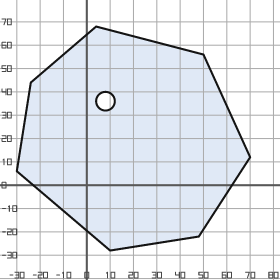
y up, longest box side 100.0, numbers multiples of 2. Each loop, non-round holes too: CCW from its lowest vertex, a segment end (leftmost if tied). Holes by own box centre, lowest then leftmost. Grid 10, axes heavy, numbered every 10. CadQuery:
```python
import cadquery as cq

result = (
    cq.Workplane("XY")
    .moveTo(10.0, -28.0)
    .lineTo(48.0, -22.0)
    .lineTo(70.0, 12.0)
    .lineTo(50.0, 56.0)
    .lineTo(4.0, 68.0)
    .lineTo(-24.0, 44.0)
    .lineTo(-30.0, 6.0)
    .close()
    .moveTo(8.0, 36.0)
    .circle(4.0)
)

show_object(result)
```